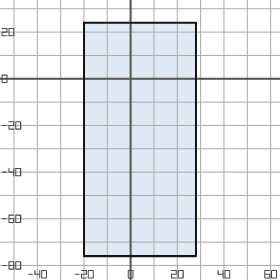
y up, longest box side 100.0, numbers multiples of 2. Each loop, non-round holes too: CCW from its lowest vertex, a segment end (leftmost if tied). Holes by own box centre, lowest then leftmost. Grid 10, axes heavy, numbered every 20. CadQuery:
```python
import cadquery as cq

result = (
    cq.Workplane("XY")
    .moveTo(-20.0, -76.0)
    .lineTo(28.0, -76.0)
    .lineTo(28.0, 24.0)
    .lineTo(-20.0, 24.0)
    .close()
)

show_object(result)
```